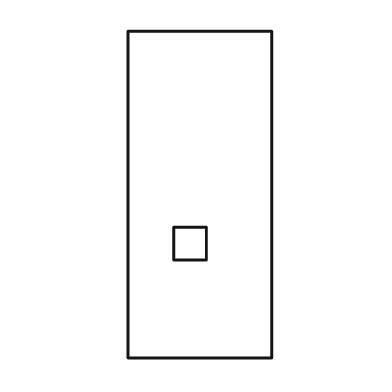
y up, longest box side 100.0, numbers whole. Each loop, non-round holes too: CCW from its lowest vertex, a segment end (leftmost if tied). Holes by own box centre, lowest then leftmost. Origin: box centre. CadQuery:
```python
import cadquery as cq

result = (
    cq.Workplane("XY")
    .moveTo(-22.0, -50.0)
    .lineTo(22.0, -50.0)
    .lineTo(22.0, 50.0)
    .lineTo(-22.0, 50.0)
    .close()
    .moveTo(-8.0, -20.0)
    .lineTo(2.0, -20.0)
    .lineTo(2.0, -10.0)
    .lineTo(-8.0, -10.0)
    .close()
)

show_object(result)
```